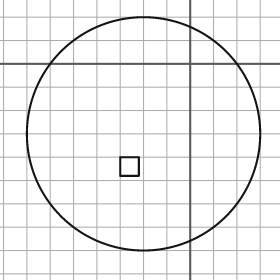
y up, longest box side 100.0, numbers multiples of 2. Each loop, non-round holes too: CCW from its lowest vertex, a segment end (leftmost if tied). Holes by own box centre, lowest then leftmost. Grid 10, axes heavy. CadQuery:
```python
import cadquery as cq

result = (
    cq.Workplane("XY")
    .moveTo(-20.0, -30.0)
    .circle(50.0)
    .moveTo(-30.0, -48.0)
    .lineTo(-22.0, -48.0)
    .lineTo(-22.0, -40.0)
    .lineTo(-30.0, -40.0)
    .close()
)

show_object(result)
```